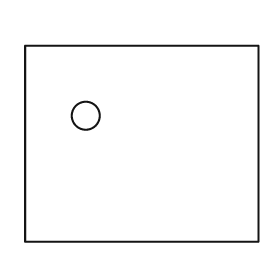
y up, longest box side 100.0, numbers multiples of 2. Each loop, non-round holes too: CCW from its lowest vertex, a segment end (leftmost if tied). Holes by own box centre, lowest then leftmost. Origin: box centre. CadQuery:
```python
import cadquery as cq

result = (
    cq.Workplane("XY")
    .moveTo(-50.0, -42.0)
    .lineTo(50.0, -42.0)
    .lineTo(50.0, 42.0)
    .lineTo(-50.0, 42.0)
    .close()
    .moveTo(-24.0, 12.0)
    .circle(6.0)
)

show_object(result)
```